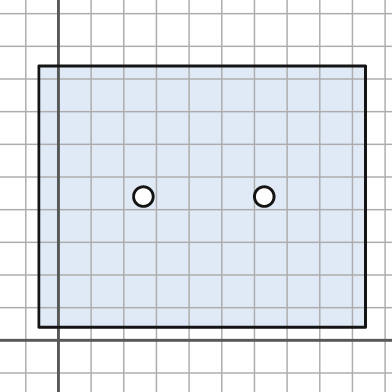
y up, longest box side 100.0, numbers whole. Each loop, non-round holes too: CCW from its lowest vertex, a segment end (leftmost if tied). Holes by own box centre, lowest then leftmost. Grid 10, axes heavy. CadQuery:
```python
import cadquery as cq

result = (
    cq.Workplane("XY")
    .moveTo(-6.0, 4.0)
    .lineTo(94.0, 4.0)
    .lineTo(94.0, 84.0)
    .lineTo(-6.0, 84.0)
    .close()
    .moveTo(26.0, 44.0)
    .circle(3.0)
    .moveTo(63.0, 44.0)
    .circle(3.0)
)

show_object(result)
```